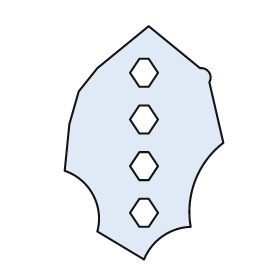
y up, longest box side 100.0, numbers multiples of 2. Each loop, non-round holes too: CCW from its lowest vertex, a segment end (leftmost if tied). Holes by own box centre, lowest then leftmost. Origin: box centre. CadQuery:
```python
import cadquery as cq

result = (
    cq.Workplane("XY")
    .moveTo(0.0, -50.0)
    .threePointArc((8.0, -40.0), (20.0, -36.0))
    .threePointArc((22.0, -16.0), (34.0, 0.0))
    .lineTo(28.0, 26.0)
    .threePointArc((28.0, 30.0), (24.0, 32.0))
    .lineTo(2.0, 50.0)
    .lineTo(-20.0, 32.0)
    .lineTo(-28.0, 22.0)
    .lineTo(-32.0, 8.0)
    .lineTo(-34.0, -12.0)
    .threePointArc((-22.0, -22.0), (-20.0, -38.0))
    .close()
    .moveTo(-2.0, -36.0)
    .lineTo(2.0, -36.0)
    .lineTo(6.0, -30.0)
    .lineTo(2.0, -24.0)
    .lineTo(-2.0, -24.0)
    .lineTo(-6.0, -30.0)
    .close()
    .moveTo(-2.0, -16.0)
    .lineTo(2.0, -16.0)
    .lineTo(6.0, -10.0)
    .lineTo(2.0, -4.0)
    .lineTo(-2.0, -4.0)
    .lineTo(-6.0, -10.0)
    .close()
    .moveTo(-2.0, 4.0)
    .lineTo(2.0, 4.0)
    .lineTo(6.0, 10.0)
    .lineTo(2.0, 16.0)
    .lineTo(-2.0, 16.0)
    .lineTo(-6.0, 10.0)
    .close()
    .moveTo(-2.0, 24.0)
    .lineTo(2.0, 24.0)
    .lineTo(6.0, 30.0)
    .lineTo(2.0, 36.0)
    .lineTo(-2.0, 36.0)
    .lineTo(-6.0, 30.0)
    .close()
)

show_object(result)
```